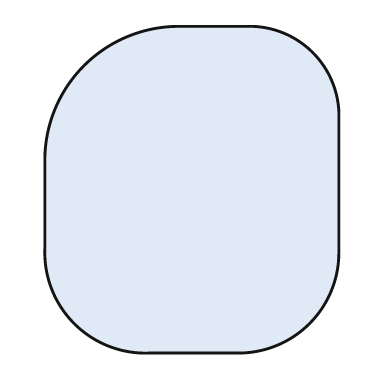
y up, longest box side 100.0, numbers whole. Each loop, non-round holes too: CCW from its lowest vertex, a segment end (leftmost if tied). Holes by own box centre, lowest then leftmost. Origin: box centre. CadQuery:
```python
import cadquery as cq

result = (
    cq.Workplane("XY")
    .moveTo(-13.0, -50.0)
    .lineTo(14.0, -50.0)
    .threePointArc((36.0, -41.0), (45.0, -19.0))
    .lineTo(45.0, 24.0)
    .threePointArc((37.0, 42.0), (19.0, 50.0))
    .lineTo(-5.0, 50.0)
    .threePointArc((-33.0, 38.0), (-45.0, 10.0))
    .lineTo(-45.0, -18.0)
    .threePointArc((-36.0, -41.0), (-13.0, -50.0))
    .close()
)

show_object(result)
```